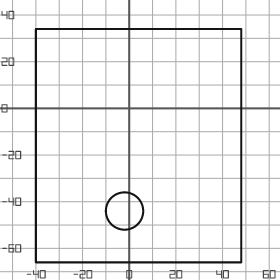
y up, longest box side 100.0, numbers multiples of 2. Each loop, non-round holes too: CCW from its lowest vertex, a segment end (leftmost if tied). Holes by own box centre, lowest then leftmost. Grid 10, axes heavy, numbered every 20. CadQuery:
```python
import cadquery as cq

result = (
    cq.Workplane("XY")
    .moveTo(-40.0, -66.0)
    .lineTo(48.0, -66.0)
    .lineTo(48.0, 34.0)
    .lineTo(-40.0, 34.0)
    .close()
    .moveTo(-2.0, -44.0)
    .circle(8.0)
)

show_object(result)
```